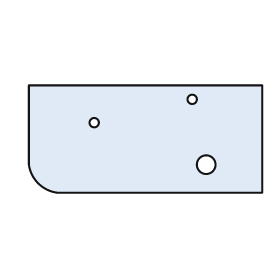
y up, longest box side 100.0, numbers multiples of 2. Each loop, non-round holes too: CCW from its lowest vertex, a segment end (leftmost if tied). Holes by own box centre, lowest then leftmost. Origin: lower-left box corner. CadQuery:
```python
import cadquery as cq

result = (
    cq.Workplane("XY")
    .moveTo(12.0, 0.0)
    .lineTo(100.0, 0.0)
    .lineTo(100.0, 46.0)
    .lineTo(0.0, 46.0)
    .lineTo(0.0, 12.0)
    .threePointArc((4.0, 4.0), (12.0, 0.0))
    .close()
    .moveTo(76.0, 12.0)
    .circle(4.0)
    .moveTo(28.0, 30.0)
    .circle(2.0)
    .moveTo(70.0, 40.0)
    .circle(2.0)
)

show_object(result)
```